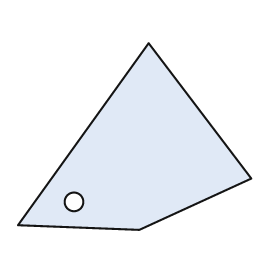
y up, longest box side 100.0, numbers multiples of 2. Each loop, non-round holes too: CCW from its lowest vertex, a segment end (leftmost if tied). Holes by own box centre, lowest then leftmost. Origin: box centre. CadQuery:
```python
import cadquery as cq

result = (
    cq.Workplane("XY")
    .moveTo(2.0, -40.0)
    .lineTo(50.0, -18.0)
    .lineTo(6.0, 40.0)
    .lineTo(-50.0, -38.0)
    .close()
    .moveTo(-26.0, -28.0)
    .circle(4.0)
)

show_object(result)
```